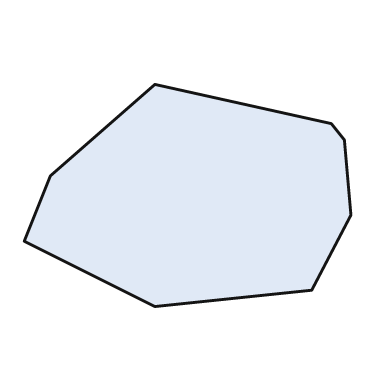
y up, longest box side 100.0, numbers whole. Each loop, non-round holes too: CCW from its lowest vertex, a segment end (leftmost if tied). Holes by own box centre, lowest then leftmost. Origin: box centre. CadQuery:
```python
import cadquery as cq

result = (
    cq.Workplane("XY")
    .moveTo(-10.0, -34.0)
    .lineTo(38.0, -29.0)
    .lineTo(50.0, -6.0)
    .lineTo(48.0, 17.0)
    .lineTo(44.0, 22.0)
    .lineTo(-10.0, 34.0)
    .lineTo(-42.0, 6.0)
    .lineTo(-50.0, -14.0)
    .close()
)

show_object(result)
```